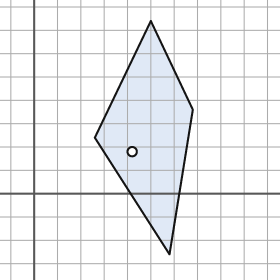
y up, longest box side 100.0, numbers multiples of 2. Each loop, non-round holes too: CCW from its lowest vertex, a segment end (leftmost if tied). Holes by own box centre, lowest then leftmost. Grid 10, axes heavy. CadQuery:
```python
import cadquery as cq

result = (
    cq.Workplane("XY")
    .moveTo(58.0, -26.0)
    .lineTo(68.0, 36.0)
    .lineTo(50.0, 74.0)
    .lineTo(26.0, 24.0)
    .close()
    .moveTo(42.0, 18.0)
    .circle(2.0)
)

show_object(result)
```